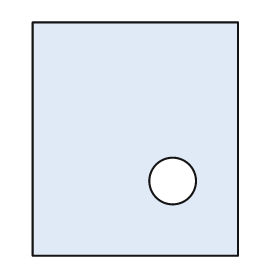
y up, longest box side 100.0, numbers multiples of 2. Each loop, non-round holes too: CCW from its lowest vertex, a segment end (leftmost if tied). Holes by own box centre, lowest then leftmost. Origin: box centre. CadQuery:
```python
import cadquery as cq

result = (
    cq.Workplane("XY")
    .moveTo(-44.0, -50.0)
    .lineTo(44.0, -50.0)
    .lineTo(44.0, 50.0)
    .lineTo(-44.0, 50.0)
    .close()
    .moveTo(16.0, -18.0)
    .circle(10.0)
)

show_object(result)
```